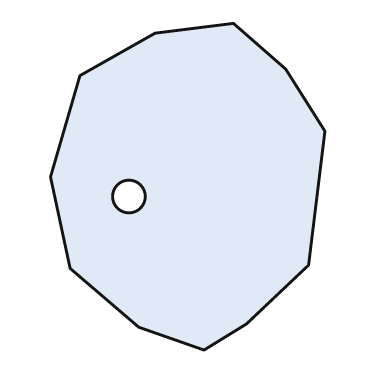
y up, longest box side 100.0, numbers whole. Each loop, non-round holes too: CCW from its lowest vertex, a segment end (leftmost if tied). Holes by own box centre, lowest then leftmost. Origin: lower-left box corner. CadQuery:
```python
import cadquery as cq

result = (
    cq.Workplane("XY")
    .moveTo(47.0, 0.0)
    .lineTo(60.0, 8.0)
    .lineTo(79.0, 26.0)
    .lineTo(84.0, 67.0)
    .lineTo(72.0, 86.0)
    .lineTo(56.0, 100.0)
    .lineTo(32.0, 97.0)
    .lineTo(9.0, 84.0)
    .lineTo(0.0, 53.0)
    .lineTo(6.0, 25.0)
    .lineTo(27.0, 7.0)
    .close()
    .moveTo(24.0, 47.0)
    .circle(5.0)
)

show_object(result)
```